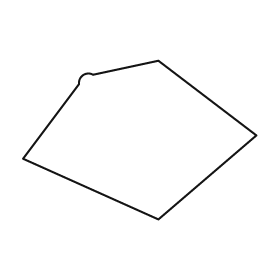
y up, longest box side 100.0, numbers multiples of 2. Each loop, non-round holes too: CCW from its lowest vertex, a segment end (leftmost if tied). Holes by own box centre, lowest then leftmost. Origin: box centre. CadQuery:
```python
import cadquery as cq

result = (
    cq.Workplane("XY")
    .moveTo(8.0, -34.0)
    .lineTo(50.0, 2.0)
    .lineTo(8.0, 34.0)
    .lineTo(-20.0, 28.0)
    .threePointArc((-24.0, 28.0), (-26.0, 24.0))
    .lineTo(-50.0, -8.0)
    .close()
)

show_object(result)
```